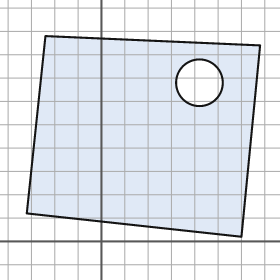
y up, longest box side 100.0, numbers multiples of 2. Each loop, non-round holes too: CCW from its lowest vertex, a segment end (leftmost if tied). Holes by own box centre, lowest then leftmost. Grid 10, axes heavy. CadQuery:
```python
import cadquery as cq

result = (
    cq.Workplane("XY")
    .moveTo(60.0, 2.0)
    .lineTo(68.0, 84.0)
    .lineTo(-24.0, 88.0)
    .lineTo(-32.0, 12.0)
    .close()
    .moveTo(42.0, 68.0)
    .circle(10.0)
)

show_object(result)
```